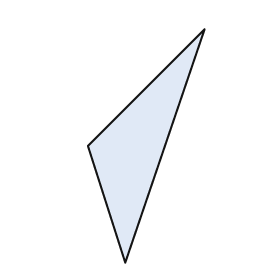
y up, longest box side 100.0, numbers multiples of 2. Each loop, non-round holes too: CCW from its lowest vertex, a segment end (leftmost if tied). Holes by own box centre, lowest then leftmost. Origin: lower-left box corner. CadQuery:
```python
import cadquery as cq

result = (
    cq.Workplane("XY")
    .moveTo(16.0, 0.0)
    .lineTo(50.0, 100.0)
    .lineTo(0.0, 50.0)
    .close()
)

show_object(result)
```